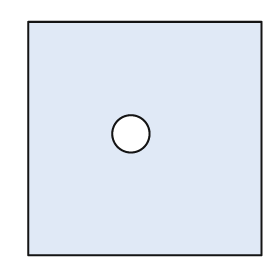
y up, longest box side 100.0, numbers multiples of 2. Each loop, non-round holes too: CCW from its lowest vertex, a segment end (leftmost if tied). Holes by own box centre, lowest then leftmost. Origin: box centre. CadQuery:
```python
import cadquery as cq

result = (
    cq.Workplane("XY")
    .moveTo(-50.0, -50.0)
    .lineTo(50.0, -50.0)
    .lineTo(50.0, 50.0)
    .lineTo(-50.0, 50.0)
    .close()
    .moveTo(-6.0, 2.0)
    .circle(8.0)
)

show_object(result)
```